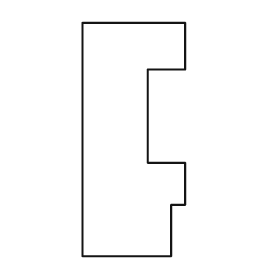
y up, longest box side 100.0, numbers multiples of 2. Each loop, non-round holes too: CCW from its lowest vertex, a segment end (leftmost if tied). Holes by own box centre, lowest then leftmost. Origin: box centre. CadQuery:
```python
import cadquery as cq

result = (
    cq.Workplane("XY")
    .moveTo(-22.0, -50.0)
    .lineTo(16.0, -50.0)
    .lineTo(16.0, -28.0)
    .lineTo(22.0, -28.0)
    .lineTo(22.0, -10.0)
    .lineTo(6.0, -10.0)
    .lineTo(6.0, 30.0)
    .lineTo(22.0, 30.0)
    .lineTo(22.0, 50.0)
    .lineTo(-22.0, 50.0)
    .close()
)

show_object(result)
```